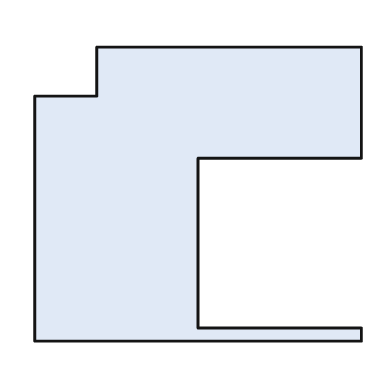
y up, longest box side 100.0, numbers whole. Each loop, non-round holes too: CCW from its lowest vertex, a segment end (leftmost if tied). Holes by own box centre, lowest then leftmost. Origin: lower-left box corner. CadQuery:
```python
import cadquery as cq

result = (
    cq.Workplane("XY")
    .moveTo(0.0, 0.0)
    .lineTo(100.0, 0.0)
    .lineTo(100.0, 4.0)
    .lineTo(50.0, 4.0)
    .lineTo(50.0, 56.0)
    .lineTo(100.0, 56.0)
    .lineTo(100.0, 90.0)
    .lineTo(19.0, 90.0)
    .lineTo(19.0, 75.0)
    .lineTo(0.0, 75.0)
    .close()
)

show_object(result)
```